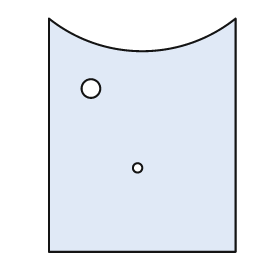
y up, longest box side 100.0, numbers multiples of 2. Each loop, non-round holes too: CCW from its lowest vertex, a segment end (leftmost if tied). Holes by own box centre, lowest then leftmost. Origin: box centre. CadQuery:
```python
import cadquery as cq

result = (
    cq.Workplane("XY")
    .moveTo(-40.0, -50.0)
    .lineTo(40.0, -50.0)
    .lineTo(40.0, 50.0)
    .threePointArc((0.0, 36.0), (-40.0, 50.0))
    .close()
    .moveTo(-2.0, -14.0)
    .circle(2.0)
    .moveTo(-22.0, 20.0)
    .circle(4.0)
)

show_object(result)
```